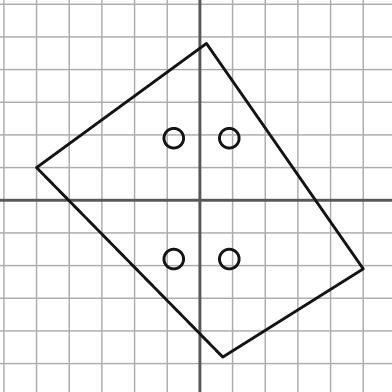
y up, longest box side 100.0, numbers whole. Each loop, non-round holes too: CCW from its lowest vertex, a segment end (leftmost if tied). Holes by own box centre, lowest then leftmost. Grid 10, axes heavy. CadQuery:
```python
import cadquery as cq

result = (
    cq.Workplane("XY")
    .moveTo(7.0, -48.0)
    .lineTo(50.0, -21.0)
    .lineTo(2.0, 48.0)
    .lineTo(-50.0, 10.0)
    .close()
    .moveTo(-8.0, -18.0)
    .circle(3.0)
    .moveTo(9.0, -18.0)
    .circle(3.0)
    .moveTo(-8.0, 19.0)
    .circle(3.0)
    .moveTo(9.0, 19.0)
    .circle(3.0)
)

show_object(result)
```